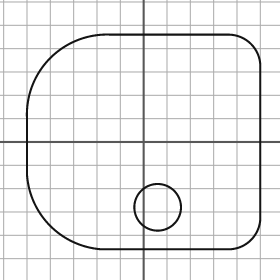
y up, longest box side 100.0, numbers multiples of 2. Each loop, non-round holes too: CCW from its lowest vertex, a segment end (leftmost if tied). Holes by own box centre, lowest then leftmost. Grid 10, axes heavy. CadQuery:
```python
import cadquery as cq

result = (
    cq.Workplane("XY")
    .moveTo(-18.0, -46.0)
    .lineTo(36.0, -46.0)
    .threePointArc((46.0, -42.0), (50.0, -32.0))
    .lineTo(50.0, 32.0)
    .threePointArc((46.0, 42.0), (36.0, 46.0))
    .lineTo(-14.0, 46.0)
    .threePointArc((-40.0, 36.0), (-50.0, 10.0))
    .lineTo(-50.0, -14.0)
    .threePointArc((-40.0, -36.0), (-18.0, -46.0))
    .close()
    .moveTo(6.0, -28.0)
    .circle(10.0)
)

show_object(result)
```